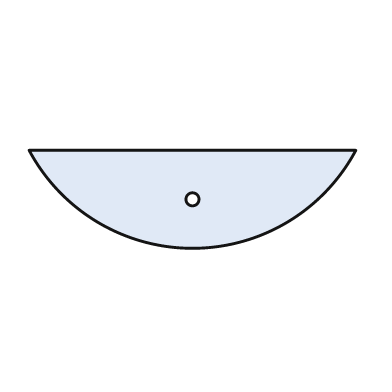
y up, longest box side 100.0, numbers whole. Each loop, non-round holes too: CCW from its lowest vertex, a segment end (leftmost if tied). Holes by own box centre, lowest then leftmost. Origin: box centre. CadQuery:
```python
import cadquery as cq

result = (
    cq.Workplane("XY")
    .moveTo(-50.0, 15.0)
    .threePointArc((0.0, -15.0), (50.0, 15.0))
    .close()
    .moveTo(0.0, 0.0)
    .circle(2.0)
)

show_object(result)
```